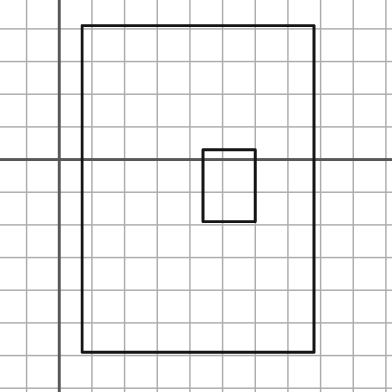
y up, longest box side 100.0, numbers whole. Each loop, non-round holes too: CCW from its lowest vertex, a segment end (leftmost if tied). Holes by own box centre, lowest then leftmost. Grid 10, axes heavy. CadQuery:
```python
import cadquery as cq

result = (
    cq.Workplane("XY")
    .moveTo(7.0, -59.0)
    .lineTo(78.0, -59.0)
    .lineTo(78.0, 41.0)
    .lineTo(7.0, 41.0)
    .close()
    .moveTo(44.0, -19.0)
    .lineTo(60.0, -19.0)
    .lineTo(60.0, 3.0)
    .lineTo(44.0, 3.0)
    .close()
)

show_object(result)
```